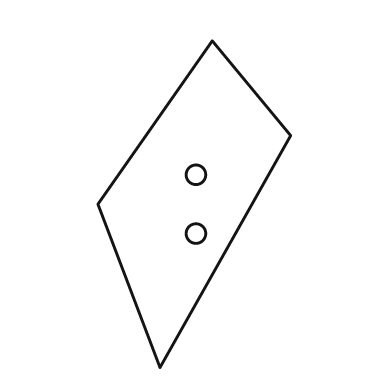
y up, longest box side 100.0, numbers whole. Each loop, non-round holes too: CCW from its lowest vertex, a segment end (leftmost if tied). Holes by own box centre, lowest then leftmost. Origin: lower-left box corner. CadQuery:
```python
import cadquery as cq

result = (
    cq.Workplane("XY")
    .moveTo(19.0, 0.0)
    .lineTo(59.0, 71.0)
    .lineTo(35.0, 100.0)
    .lineTo(0.0, 50.0)
    .close()
    .moveTo(30.0, 41.0)
    .circle(3.0)
    .moveTo(30.0, 59.0)
    .circle(3.0)
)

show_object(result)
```